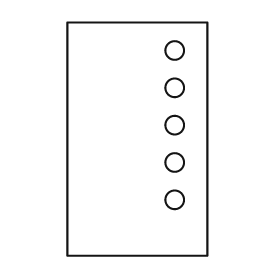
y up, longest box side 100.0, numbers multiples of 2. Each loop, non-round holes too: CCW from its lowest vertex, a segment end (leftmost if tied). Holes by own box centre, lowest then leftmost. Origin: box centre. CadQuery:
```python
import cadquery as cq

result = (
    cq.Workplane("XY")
    .moveTo(-30.0, -50.0)
    .lineTo(30.0, -50.0)
    .lineTo(30.0, 50.0)
    .lineTo(-30.0, 50.0)
    .close()
    .moveTo(16.0, -26.0)
    .circle(4.0)
    .moveTo(16.0, -10.0)
    .circle(4.0)
    .moveTo(16.0, 6.0)
    .circle(4.0)
    .moveTo(16.0, 22.0)
    .circle(4.0)
    .moveTo(16.0, 38.0)
    .circle(4.0)
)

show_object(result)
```